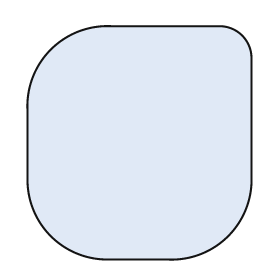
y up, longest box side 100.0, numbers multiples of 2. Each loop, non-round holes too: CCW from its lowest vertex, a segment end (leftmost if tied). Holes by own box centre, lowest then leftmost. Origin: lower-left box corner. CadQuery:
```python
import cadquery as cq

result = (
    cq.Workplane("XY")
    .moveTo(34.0, 0.0)
    .lineTo(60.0, 0.0)
    .threePointArc((86.0, 10.0), (96.0, 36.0))
    .lineTo(96.0, 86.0)
    .threePointArc((92.0, 96.0), (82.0, 100.0))
    .lineTo(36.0, 100.0)
    .threePointArc((10.0, 90.0), (0.0, 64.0))
    .lineTo(0.0, 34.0)
    .threePointArc((10.0, 10.0), (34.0, 0.0))
    .close()
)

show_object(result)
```